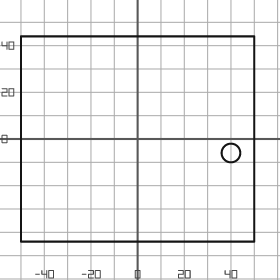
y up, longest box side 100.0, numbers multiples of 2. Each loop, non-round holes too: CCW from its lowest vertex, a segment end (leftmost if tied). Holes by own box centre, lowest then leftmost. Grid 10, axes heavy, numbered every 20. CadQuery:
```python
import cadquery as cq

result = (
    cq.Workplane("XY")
    .moveTo(-50.0, -44.0)
    .lineTo(50.0, -44.0)
    .lineTo(50.0, 44.0)
    .lineTo(-50.0, 44.0)
    .close()
    .moveTo(40.0, -6.0)
    .circle(4.0)
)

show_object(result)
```